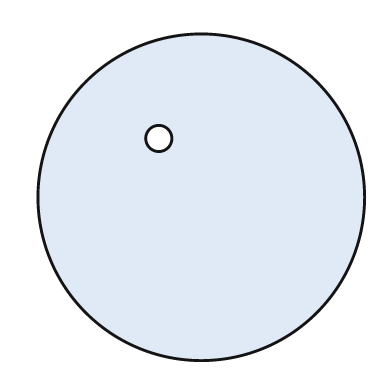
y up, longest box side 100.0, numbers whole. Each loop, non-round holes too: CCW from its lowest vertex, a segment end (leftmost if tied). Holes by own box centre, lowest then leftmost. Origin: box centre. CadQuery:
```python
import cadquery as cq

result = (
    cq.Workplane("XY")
    .moveTo(0.0, 0.0)
    .circle(50.0)
    .moveTo(-13.0, 18.0)
    .circle(4.0)
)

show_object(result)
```